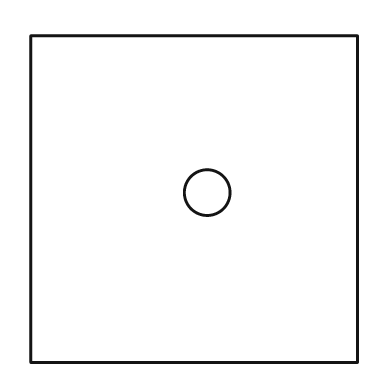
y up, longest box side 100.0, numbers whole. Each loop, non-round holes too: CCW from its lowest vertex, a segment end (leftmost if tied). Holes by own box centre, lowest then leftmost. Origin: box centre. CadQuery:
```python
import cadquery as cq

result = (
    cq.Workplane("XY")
    .moveTo(-50.0, -50.0)
    .lineTo(50.0, -50.0)
    .lineTo(50.0, 50.0)
    .lineTo(-50.0, 50.0)
    .close()
    .moveTo(4.0, 2.0)
    .circle(7.0)
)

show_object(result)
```